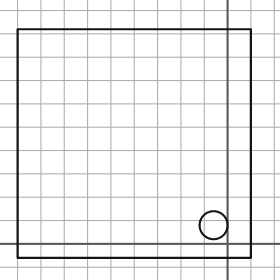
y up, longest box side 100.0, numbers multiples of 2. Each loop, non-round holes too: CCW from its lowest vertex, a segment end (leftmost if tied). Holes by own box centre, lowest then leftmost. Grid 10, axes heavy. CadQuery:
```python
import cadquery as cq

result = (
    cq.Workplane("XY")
    .moveTo(-90.0, -6.0)
    .lineTo(10.0, -6.0)
    .lineTo(10.0, 92.0)
    .lineTo(-90.0, 92.0)
    .close()
    .moveTo(-6.0, 8.0)
    .circle(6.0)
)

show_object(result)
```